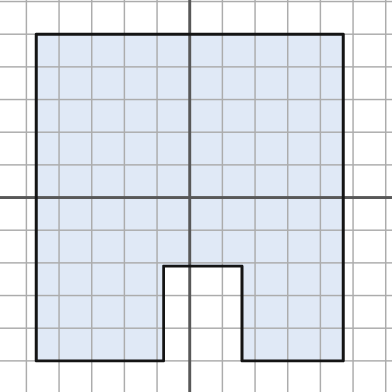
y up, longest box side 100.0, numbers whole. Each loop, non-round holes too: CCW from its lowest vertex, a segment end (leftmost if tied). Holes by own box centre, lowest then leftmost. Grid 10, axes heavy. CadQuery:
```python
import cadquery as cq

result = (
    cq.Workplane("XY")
    .moveTo(-47.0, -50.0)
    .lineTo(-8.0, -50.0)
    .lineTo(-8.0, -21.0)
    .lineTo(16.0, -21.0)
    .lineTo(16.0, -50.0)
    .lineTo(47.0, -50.0)
    .lineTo(47.0, 50.0)
    .lineTo(-47.0, 50.0)
    .close()
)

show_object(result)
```